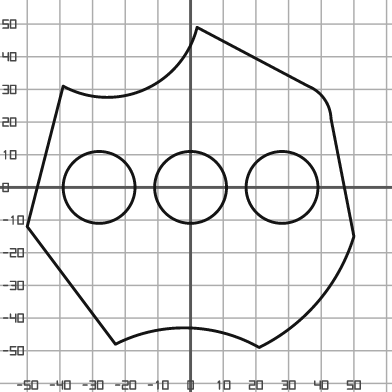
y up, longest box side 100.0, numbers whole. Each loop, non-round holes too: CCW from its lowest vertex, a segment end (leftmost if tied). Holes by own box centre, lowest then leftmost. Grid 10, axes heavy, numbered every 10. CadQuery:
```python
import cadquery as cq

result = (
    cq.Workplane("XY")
    .moveTo(21.0, -49.0)
    .threePointArc((39.0, -35.0), (50.0, -15.0))
    .lineTo(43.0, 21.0)
    .threePointArc((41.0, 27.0), (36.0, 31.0))
    .lineTo(2.0, 49.0)
    .threePointArc((-14.0, 30.0), (-39.0, 31.0))
    .lineTo(-50.0, -12.0)
    .lineTo(-23.0, -48.0)
    .threePointArc((-1.0, -43.0), (21.0, -49.0))
    .close()
    .moveTo(-28.0, 0.0)
    .circle(11.0)
    .moveTo(0.0, 0.0)
    .circle(11.0)
    .moveTo(28.0, 0.0)
    .circle(11.0)
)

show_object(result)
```